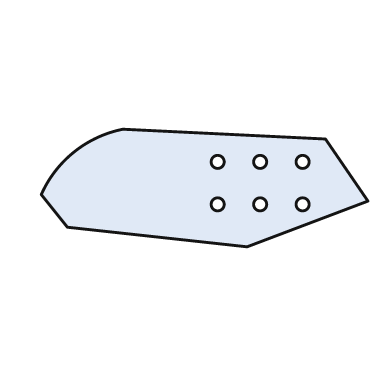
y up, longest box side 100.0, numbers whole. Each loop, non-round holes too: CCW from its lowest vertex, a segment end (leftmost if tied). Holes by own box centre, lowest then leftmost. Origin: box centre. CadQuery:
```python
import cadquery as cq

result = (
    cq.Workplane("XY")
    .moveTo(13.0, -18.0)
    .lineTo(50.0, -4.0)
    .lineTo(37.0, 15.0)
    .lineTo(-25.0, 18.0)
    .threePointArc((-40.0, 11.0), (-50.0, -2.0))
    .lineTo(-42.0, -12.0)
    .close()
    .moveTo(4.0, -5.0)
    .circle(2.0)
    .moveTo(17.0, -5.0)
    .circle(2.0)
    .moveTo(30.0, -5.0)
    .circle(2.0)
    .moveTo(4.0, 8.0)
    .circle(2.0)
    .moveTo(17.0, 8.0)
    .circle(2.0)
    .moveTo(30.0, 8.0)
    .circle(2.0)
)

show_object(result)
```